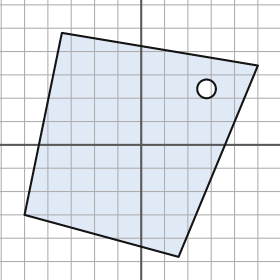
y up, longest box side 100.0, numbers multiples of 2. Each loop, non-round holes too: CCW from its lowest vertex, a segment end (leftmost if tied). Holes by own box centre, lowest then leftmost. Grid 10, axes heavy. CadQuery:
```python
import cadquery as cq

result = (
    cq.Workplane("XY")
    .moveTo(16.0, -48.0)
    .lineTo(50.0, 34.0)
    .lineTo(-34.0, 48.0)
    .lineTo(-50.0, -30.0)
    .close()
    .moveTo(28.0, 24.0)
    .circle(4.0)
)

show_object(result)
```